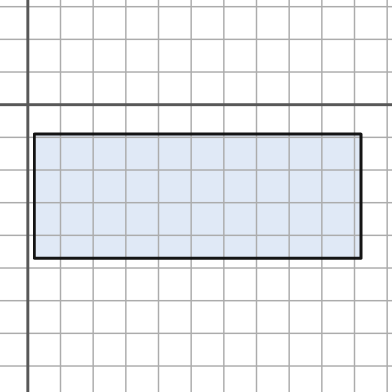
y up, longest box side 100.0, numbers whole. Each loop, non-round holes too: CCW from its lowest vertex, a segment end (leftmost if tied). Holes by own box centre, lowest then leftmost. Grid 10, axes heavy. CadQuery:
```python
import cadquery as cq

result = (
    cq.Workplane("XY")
    .moveTo(2.0, -47.0)
    .lineTo(102.0, -47.0)
    .lineTo(102.0, -9.0)
    .lineTo(2.0, -9.0)
    .close()
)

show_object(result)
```